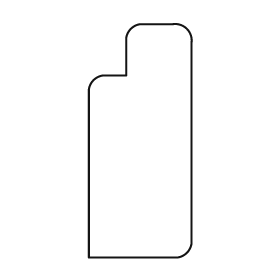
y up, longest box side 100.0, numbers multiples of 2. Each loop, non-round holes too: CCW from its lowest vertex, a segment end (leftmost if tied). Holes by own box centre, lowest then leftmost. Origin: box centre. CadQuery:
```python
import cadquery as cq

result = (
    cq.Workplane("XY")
    .moveTo(-22.0, -50.0)
    .lineTo(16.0, -50.0)
    .threePointArc((20.0, -48.0), (22.0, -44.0))
    .lineTo(22.0, 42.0)
    .threePointArc((20.0, 48.0), (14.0, 50.0))
    .lineTo(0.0, 50.0)
    .threePointArc((-4.0, 48.0), (-6.0, 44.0))
    .lineTo(-6.0, 28.0)
    .lineTo(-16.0, 28.0)
    .threePointArc((-20.0, 26.0), (-22.0, 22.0))
    .close()
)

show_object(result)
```